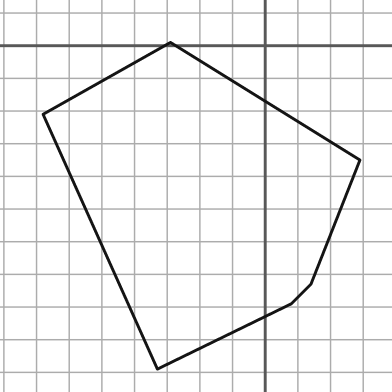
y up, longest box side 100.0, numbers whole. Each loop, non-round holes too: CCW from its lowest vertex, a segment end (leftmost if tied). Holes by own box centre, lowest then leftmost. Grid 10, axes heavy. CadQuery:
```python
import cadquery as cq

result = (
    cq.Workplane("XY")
    .moveTo(-33.0, -99.0)
    .lineTo(8.0, -79.0)
    .lineTo(14.0, -73.0)
    .lineTo(29.0, -35.0)
    .lineTo(-29.0, 1.0)
    .lineTo(-68.0, -21.0)
    .close()
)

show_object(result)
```